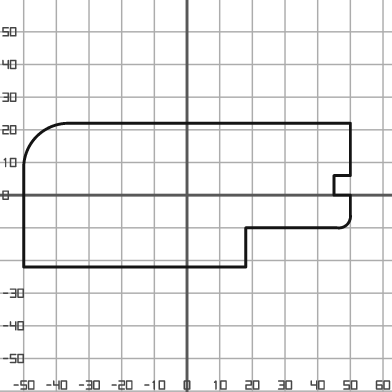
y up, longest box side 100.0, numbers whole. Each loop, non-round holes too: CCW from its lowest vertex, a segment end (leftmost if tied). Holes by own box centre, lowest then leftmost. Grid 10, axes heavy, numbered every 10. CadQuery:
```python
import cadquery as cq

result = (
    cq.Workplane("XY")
    .moveTo(-50.0, -22.0)
    .lineTo(18.0, -22.0)
    .lineTo(18.0, -10.0)
    .lineTo(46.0, -10.0)
    .threePointArc((49.0, -9.0), (50.0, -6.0))
    .lineTo(50.0, 0.0)
    .lineTo(45.0, 0.0)
    .lineTo(45.0, 6.0)
    .lineTo(50.0, 6.0)
    .lineTo(50.0, 22.0)
    .lineTo(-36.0, 22.0)
    .threePointArc((-46.0, 18.0), (-50.0, 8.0))
    .close()
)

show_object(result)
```